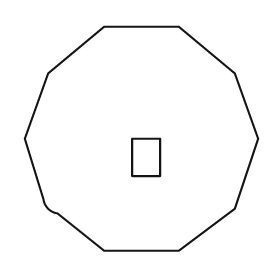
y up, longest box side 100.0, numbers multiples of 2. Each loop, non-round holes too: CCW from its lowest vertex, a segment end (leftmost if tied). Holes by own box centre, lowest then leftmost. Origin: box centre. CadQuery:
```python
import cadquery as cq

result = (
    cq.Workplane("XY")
    .moveTo(-16.0, -48.0)
    .lineTo(16.0, -48.0)
    .lineTo(40.0, -30.0)
    .lineTo(50.0, 0.0)
    .lineTo(40.0, 28.0)
    .lineTo(16.0, 48.0)
    .lineTo(-16.0, 48.0)
    .lineTo(-40.0, 28.0)
    .lineTo(-50.0, 0.0)
    .lineTo(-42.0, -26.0)
    .threePointArc((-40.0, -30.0), (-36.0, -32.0))
    .close()
    .moveTo(-4.0, -16.0)
    .lineTo(8.0, -16.0)
    .lineTo(8.0, 0.0)
    .lineTo(-4.0, 0.0)
    .close()
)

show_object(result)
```